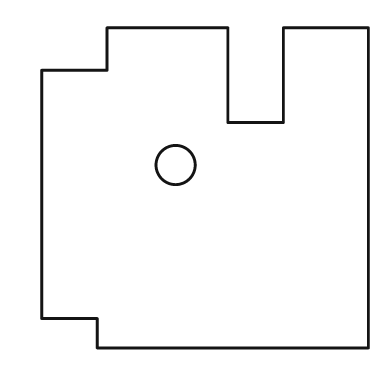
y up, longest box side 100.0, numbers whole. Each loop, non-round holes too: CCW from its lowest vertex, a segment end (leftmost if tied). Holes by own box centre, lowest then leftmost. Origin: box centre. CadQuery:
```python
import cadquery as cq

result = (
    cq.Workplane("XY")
    .moveTo(-33.0, -49.0)
    .lineTo(50.0, -49.0)
    .lineTo(50.0, 49.0)
    .lineTo(24.0, 49.0)
    .lineTo(24.0, 20.0)
    .lineTo(7.0, 20.0)
    .lineTo(7.0, 49.0)
    .lineTo(-30.0, 49.0)
    .lineTo(-30.0, 36.0)
    .lineTo(-50.0, 36.0)
    .lineTo(-50.0, -40.0)
    .lineTo(-33.0, -40.0)
    .close()
    .moveTo(-9.0, 7.0)
    .circle(6.0)
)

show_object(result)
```